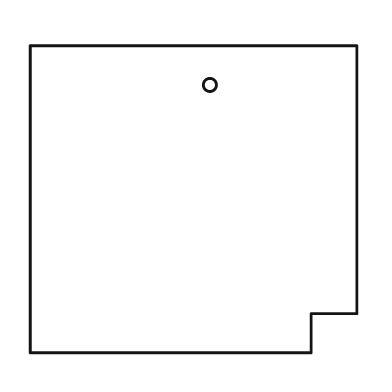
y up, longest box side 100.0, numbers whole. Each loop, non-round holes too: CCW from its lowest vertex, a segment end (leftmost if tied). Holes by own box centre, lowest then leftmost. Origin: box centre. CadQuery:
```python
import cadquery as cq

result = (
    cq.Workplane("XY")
    .moveTo(-50.0, -47.0)
    .lineTo(36.0, -47.0)
    .lineTo(36.0, -35.0)
    .lineTo(50.0, -35.0)
    .lineTo(50.0, 47.0)
    .lineTo(-50.0, 47.0)
    .close()
    .moveTo(5.0, 35.0)
    .circle(2.0)
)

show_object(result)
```